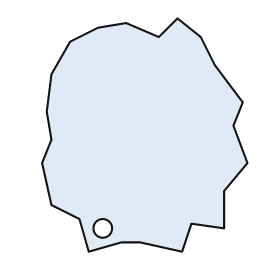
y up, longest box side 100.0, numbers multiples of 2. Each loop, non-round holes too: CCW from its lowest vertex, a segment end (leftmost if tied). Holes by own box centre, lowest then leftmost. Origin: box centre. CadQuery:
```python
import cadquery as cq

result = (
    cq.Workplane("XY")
    .moveTo(-24.0, -50.0)
    .lineTo(-10.0, -46.0)
    .lineTo(-2.0, -46.0)
    .lineTo(16.0, -50.0)
    .lineTo(20.0, -38.0)
    .lineTo(34.0, -40.0)
    .lineTo(34.0, -24.0)
    .lineTo(44.0, -12.0)
    .lineTo(38.0, 4.0)
    .lineTo(42.0, 14.0)
    .lineTo(30.0, 30.0)
    .lineTo(24.0, 42.0)
    .lineTo(14.0, 50.0)
    .lineTo(6.0, 42.0)
    .lineTo(-8.0, 48.0)
    .lineTo(-20.0, 46.0)
    .lineTo(-32.0, 40.0)
    .lineTo(-40.0, 26.0)
    .lineTo(-42.0, 10.0)
    .lineTo(-40.0, -2.0)
    .lineTo(-44.0, -12.0)
    .lineTo(-40.0, -30.0)
    .lineTo(-28.0, -36.0)
    .close()
    .moveTo(-18.0, -40.0)
    .circle(4.0)
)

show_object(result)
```